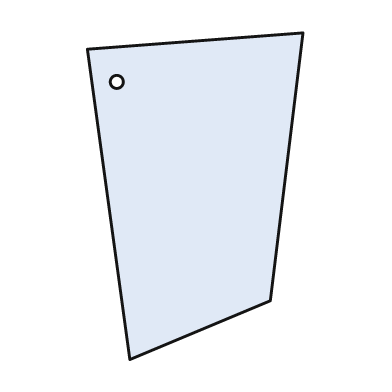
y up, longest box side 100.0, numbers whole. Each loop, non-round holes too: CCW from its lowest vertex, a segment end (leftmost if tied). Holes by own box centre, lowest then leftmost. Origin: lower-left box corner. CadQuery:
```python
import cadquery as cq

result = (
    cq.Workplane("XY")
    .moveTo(13.0, 0.0)
    .lineTo(56.0, 18.0)
    .lineTo(66.0, 100.0)
    .lineTo(0.0, 95.0)
    .close()
    .moveTo(9.0, 85.0)
    .circle(2.0)
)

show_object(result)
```